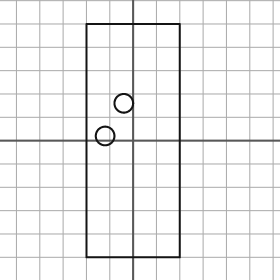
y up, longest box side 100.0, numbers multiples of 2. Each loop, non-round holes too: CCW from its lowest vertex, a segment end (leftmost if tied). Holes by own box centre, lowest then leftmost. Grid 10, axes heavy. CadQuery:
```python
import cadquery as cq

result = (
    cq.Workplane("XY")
    .moveTo(-20.0, -50.0)
    .lineTo(20.0, -50.0)
    .lineTo(20.0, 50.0)
    .lineTo(-20.0, 50.0)
    .close()
    .moveTo(-12.0, 2.0)
    .circle(4.0)
    .moveTo(-4.0, 16.0)
    .circle(4.0)
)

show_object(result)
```